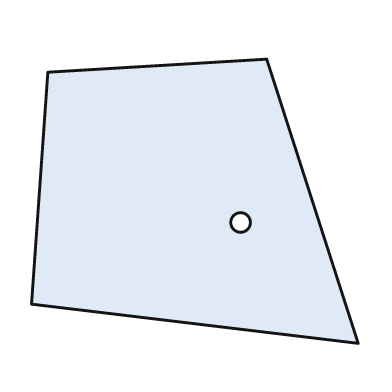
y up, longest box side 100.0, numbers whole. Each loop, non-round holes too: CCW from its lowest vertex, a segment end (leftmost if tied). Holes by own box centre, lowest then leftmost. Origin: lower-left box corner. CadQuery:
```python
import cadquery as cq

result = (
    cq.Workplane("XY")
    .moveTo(100.0, 0.0)
    .lineTo(72.0, 87.0)
    .lineTo(5.0, 83.0)
    .lineTo(0.0, 12.0)
    .close()
    .moveTo(64.0, 37.0)
    .circle(3.0)
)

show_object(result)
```